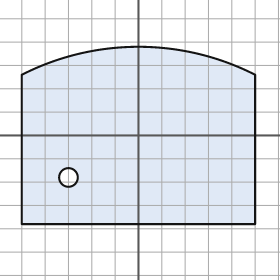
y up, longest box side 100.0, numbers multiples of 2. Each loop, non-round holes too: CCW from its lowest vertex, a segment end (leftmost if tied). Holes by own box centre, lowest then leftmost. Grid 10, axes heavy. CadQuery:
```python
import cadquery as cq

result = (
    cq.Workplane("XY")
    .moveTo(-50.0, -38.0)
    .lineTo(50.0, -38.0)
    .lineTo(50.0, 26.0)
    .threePointArc((0.0, 38.0), (-50.0, 26.0))
    .close()
    .moveTo(-30.0, -18.0)
    .circle(4.0)
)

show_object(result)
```